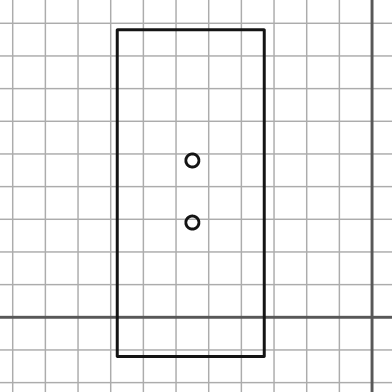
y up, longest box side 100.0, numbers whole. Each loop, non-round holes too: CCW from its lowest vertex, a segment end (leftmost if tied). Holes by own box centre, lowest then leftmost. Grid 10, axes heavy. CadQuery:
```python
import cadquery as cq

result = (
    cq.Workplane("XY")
    .moveTo(-78.0, -12.0)
    .lineTo(-33.0, -12.0)
    .lineTo(-33.0, 88.0)
    .lineTo(-78.0, 88.0)
    .close()
    .moveTo(-55.0, 29.0)
    .circle(2.0)
    .moveTo(-55.0, 48.0)
    .circle(2.0)
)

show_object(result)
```